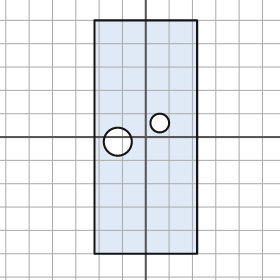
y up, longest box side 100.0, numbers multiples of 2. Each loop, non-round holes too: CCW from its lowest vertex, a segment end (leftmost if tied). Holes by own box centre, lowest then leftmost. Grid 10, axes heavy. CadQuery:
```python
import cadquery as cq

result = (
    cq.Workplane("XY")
    .moveTo(-22.0, -50.0)
    .lineTo(22.0, -50.0)
    .lineTo(22.0, 50.0)
    .lineTo(-22.0, 50.0)
    .close()
    .moveTo(-12.0, -2.0)
    .circle(6.0)
    .moveTo(6.0, 6.0)
    .circle(4.0)
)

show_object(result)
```